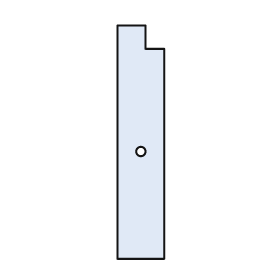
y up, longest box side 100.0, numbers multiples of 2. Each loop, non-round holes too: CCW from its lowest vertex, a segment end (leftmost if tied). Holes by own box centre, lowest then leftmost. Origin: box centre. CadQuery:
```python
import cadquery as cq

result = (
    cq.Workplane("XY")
    .moveTo(-10.0, -50.0)
    .lineTo(10.0, -50.0)
    .lineTo(10.0, 40.0)
    .lineTo(2.0, 40.0)
    .lineTo(2.0, 50.0)
    .lineTo(-10.0, 50.0)
    .close()
    .moveTo(0.0, -4.0)
    .circle(2.0)
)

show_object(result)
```